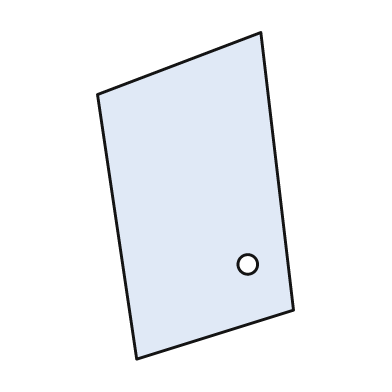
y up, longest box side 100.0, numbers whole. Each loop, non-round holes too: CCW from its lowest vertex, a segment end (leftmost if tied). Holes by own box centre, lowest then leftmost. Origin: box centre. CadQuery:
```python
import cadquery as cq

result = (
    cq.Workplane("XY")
    .moveTo(-18.0, -50.0)
    .lineTo(30.0, -35.0)
    .lineTo(20.0, 50.0)
    .lineTo(-30.0, 31.0)
    .close()
    .moveTo(16.0, -21.0)
    .circle(3.0)
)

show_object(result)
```